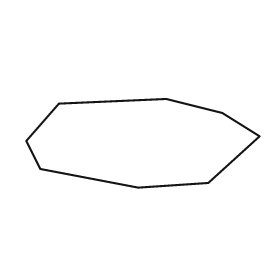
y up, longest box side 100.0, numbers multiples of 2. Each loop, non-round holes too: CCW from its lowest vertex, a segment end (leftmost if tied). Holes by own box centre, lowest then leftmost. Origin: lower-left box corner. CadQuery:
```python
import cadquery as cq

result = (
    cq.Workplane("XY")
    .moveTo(48.0, 0.0)
    .lineTo(78.0, 2.0)
    .lineTo(100.0, 22.0)
    .lineTo(84.0, 32.0)
    .lineTo(60.0, 38.0)
    .lineTo(14.0, 36.0)
    .lineTo(0.0, 20.0)
    .lineTo(6.0, 8.0)
    .close()
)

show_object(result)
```